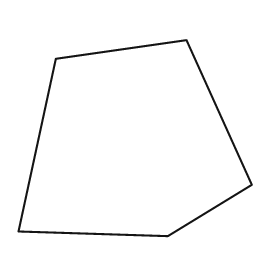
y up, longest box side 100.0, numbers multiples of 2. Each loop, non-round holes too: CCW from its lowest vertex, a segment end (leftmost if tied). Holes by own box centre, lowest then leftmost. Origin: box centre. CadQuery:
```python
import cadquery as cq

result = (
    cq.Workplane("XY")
    .moveTo(14.0, -42.0)
    .lineTo(50.0, -20.0)
    .lineTo(22.0, 42.0)
    .lineTo(-34.0, 34.0)
    .lineTo(-50.0, -40.0)
    .close()
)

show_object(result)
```